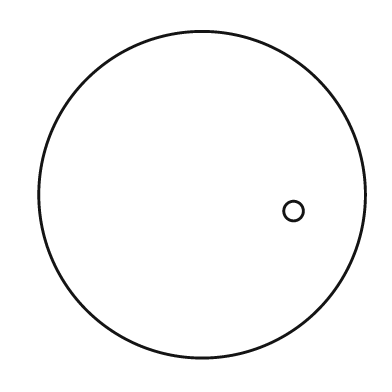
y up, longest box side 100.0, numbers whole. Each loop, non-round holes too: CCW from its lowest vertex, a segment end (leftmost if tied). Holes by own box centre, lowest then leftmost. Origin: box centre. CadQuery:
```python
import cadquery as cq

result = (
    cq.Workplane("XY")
    .moveTo(0.0, 0.0)
    .circle(50.0)
    .moveTo(28.0, -5.0)
    .circle(3.0)
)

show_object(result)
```